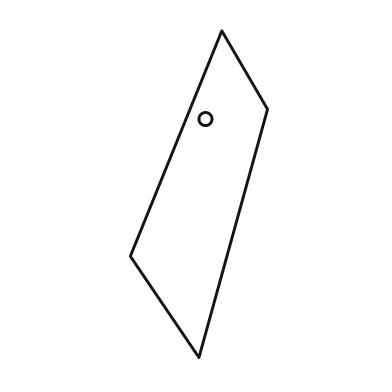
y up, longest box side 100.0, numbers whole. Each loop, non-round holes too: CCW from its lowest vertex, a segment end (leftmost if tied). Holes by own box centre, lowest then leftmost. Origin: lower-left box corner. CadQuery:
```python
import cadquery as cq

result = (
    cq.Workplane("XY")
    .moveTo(21.0, 0.0)
    .lineTo(42.0, 76.0)
    .lineTo(28.0, 100.0)
    .lineTo(0.0, 31.0)
    .close()
    .moveTo(23.0, 73.0)
    .circle(2.0)
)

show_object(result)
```